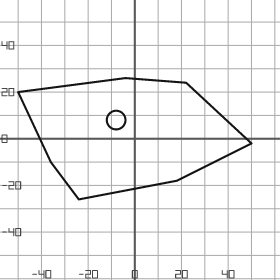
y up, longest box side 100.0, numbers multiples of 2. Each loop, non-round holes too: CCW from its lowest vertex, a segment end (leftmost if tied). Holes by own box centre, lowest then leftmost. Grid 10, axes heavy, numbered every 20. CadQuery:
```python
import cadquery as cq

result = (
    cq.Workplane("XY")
    .moveTo(-24.0, -26.0)
    .lineTo(18.0, -18.0)
    .lineTo(50.0, -2.0)
    .lineTo(22.0, 24.0)
    .lineTo(-4.0, 26.0)
    .lineTo(-50.0, 20.0)
    .lineTo(-36.0, -10.0)
    .close()
    .moveTo(-8.0, 8.0)
    .circle(4.0)
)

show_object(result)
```